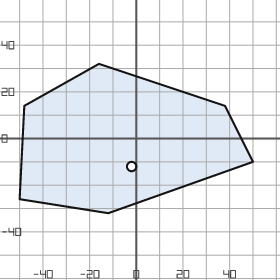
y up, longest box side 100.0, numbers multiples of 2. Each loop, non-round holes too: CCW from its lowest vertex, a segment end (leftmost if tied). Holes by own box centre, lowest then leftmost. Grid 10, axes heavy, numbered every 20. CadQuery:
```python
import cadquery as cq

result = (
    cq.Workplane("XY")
    .moveTo(-12.0, -32.0)
    .lineTo(50.0, -10.0)
    .lineTo(38.0, 14.0)
    .lineTo(-16.0, 32.0)
    .lineTo(-48.0, 14.0)
    .lineTo(-50.0, -26.0)
    .close()
    .moveTo(-2.0, -12.0)
    .circle(2.0)
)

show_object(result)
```